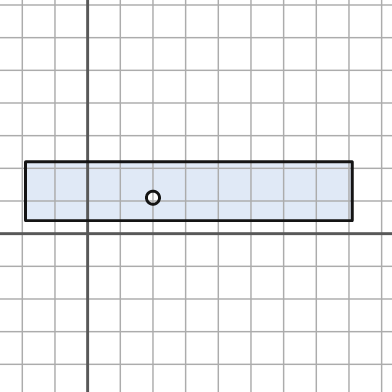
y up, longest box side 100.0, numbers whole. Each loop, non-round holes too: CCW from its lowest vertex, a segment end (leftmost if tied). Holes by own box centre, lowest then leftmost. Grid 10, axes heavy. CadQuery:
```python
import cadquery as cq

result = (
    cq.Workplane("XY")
    .moveTo(-19.0, 4.0)
    .lineTo(81.0, 4.0)
    .lineTo(81.0, 22.0)
    .lineTo(-19.0, 22.0)
    .close()
    .moveTo(20.0, 11.0)
    .circle(2.0)
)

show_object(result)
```